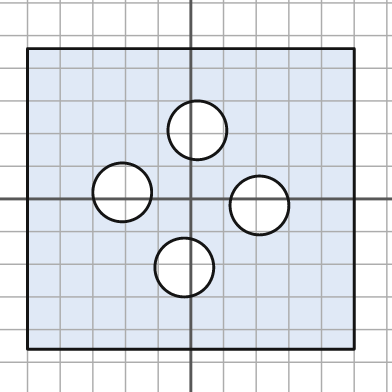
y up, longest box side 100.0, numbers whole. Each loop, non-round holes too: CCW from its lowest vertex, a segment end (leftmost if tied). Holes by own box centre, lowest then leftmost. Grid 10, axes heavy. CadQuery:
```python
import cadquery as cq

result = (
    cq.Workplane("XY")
    .moveTo(-50.0, -46.0)
    .lineTo(50.0, -46.0)
    .lineTo(50.0, 46.0)
    .lineTo(-50.0, 46.0)
    .close()
    .moveTo(-2.0, -21.0)
    .circle(9.0)
    .moveTo(21.0, -2.0)
    .circle(9.0)
    .moveTo(-21.0, 2.0)
    .circle(9.0)
    .moveTo(2.0, 21.0)
    .circle(9.0)
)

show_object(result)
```